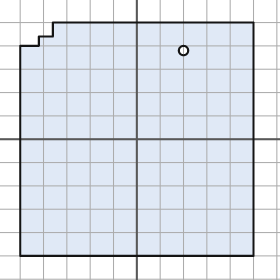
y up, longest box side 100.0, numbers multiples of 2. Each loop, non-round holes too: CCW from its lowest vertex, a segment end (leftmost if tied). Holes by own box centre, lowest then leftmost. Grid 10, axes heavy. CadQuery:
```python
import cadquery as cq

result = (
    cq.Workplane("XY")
    .moveTo(-50.0, -50.0)
    .lineTo(50.0, -50.0)
    .lineTo(50.0, 50.0)
    .lineTo(-36.0, 50.0)
    .lineTo(-36.0, 44.0)
    .lineTo(-42.0, 44.0)
    .lineTo(-42.0, 40.0)
    .lineTo(-50.0, 40.0)
    .close()
    .moveTo(20.0, 38.0)
    .circle(2.0)
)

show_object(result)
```